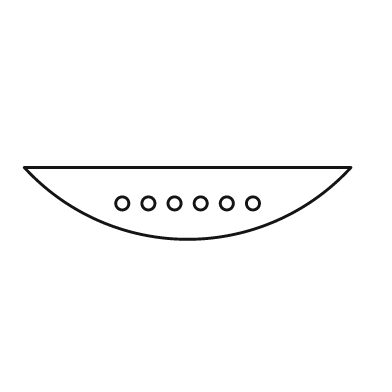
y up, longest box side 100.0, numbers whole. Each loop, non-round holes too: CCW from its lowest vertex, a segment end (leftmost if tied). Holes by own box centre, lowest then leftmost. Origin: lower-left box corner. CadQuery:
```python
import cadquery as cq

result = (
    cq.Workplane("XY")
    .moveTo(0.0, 22.0)
    .threePointArc((50.0, 0.0), (100.0, 22.0))
    .close()
    .moveTo(30.0, 11.0)
    .circle(2.0)
    .moveTo(38.0, 11.0)
    .circle(2.0)
    .moveTo(46.0, 11.0)
    .circle(2.0)
    .moveTo(54.0, 11.0)
    .circle(2.0)
    .moveTo(62.0, 11.0)
    .circle(2.0)
    .moveTo(70.0, 11.0)
    .circle(2.0)
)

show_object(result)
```